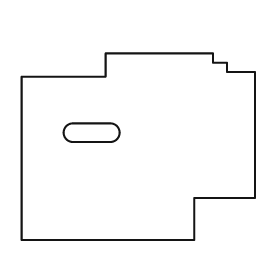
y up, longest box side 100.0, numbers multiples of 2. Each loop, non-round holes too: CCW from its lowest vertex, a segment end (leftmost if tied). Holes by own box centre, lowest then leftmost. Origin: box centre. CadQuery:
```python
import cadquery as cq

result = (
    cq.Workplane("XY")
    .moveTo(-50.0, -40.0)
    .lineTo(24.0, -40.0)
    .lineTo(24.0, -22.0)
    .lineTo(50.0, -22.0)
    .lineTo(50.0, 32.0)
    .lineTo(38.0, 32.0)
    .lineTo(38.0, 36.0)
    .lineTo(32.0, 36.0)
    .lineTo(32.0, 40.0)
    .lineTo(-14.0, 40.0)
    .lineTo(-14.0, 30.0)
    .lineTo(-50.0, 30.0)
    .close()
    .moveTo(-28.0, 2.0)
    .lineTo(-12.0, 2.0)
    .threePointArc((-8.0, 6.0), (-12.0, 10.0))
    .lineTo(-28.0, 10.0)
    .threePointArc((-32.0, 6.0), (-28.0, 2.0))
    .close()
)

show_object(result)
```